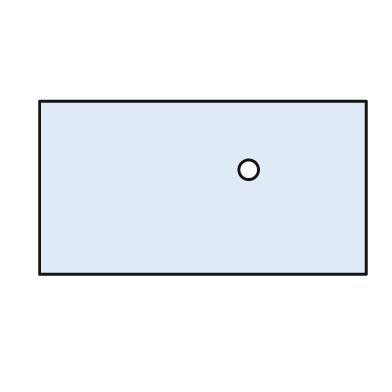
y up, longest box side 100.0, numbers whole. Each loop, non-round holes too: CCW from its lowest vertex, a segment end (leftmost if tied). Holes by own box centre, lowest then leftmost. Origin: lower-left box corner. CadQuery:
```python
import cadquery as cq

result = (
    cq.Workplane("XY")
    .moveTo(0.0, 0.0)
    .lineTo(100.0, 0.0)
    .lineTo(100.0, 53.0)
    .lineTo(0.0, 53.0)
    .close()
    .moveTo(64.0, 32.0)
    .circle(3.0)
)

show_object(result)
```